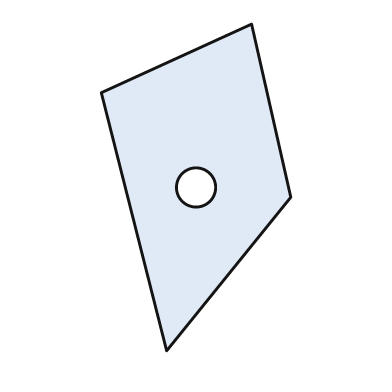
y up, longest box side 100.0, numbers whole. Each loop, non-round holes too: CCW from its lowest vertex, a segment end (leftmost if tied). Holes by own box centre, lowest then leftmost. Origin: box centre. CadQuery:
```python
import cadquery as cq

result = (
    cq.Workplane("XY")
    .moveTo(-9.0, -50.0)
    .lineTo(29.0, -3.0)
    .lineTo(17.0, 50.0)
    .lineTo(-29.0, 29.0)
    .close()
    .moveTo(0.0, 0.0)
    .circle(6.0)
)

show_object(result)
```